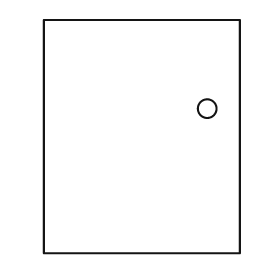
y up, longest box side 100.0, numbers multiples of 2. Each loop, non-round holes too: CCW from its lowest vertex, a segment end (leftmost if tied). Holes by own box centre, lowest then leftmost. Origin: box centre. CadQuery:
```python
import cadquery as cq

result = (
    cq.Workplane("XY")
    .moveTo(-42.0, -50.0)
    .lineTo(42.0, -50.0)
    .lineTo(42.0, 50.0)
    .lineTo(-42.0, 50.0)
    .close()
    .moveTo(28.0, 12.0)
    .circle(4.0)
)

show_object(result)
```